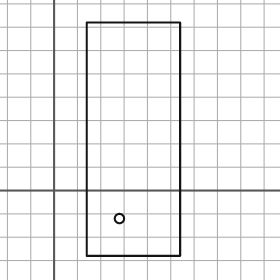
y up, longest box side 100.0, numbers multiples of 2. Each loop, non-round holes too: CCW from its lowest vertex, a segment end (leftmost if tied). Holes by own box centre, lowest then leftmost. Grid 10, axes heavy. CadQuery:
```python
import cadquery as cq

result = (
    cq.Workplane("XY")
    .moveTo(14.0, -28.0)
    .lineTo(54.0, -28.0)
    .lineTo(54.0, 72.0)
    .lineTo(14.0, 72.0)
    .close()
    .moveTo(28.0, -12.0)
    .circle(2.0)
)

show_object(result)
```